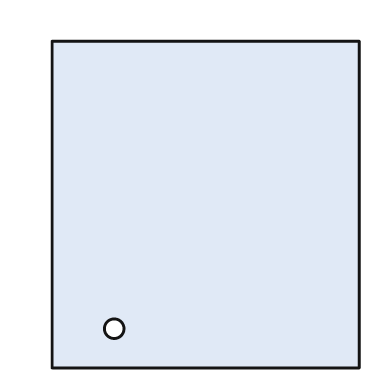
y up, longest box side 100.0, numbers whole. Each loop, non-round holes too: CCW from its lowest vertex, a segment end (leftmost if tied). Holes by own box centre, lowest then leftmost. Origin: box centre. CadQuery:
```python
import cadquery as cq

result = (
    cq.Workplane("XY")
    .moveTo(-47.0, -50.0)
    .lineTo(47.0, -50.0)
    .lineTo(47.0, 50.0)
    .lineTo(-47.0, 50.0)
    .close()
    .moveTo(-28.0, -38.0)
    .circle(3.0)
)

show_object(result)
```